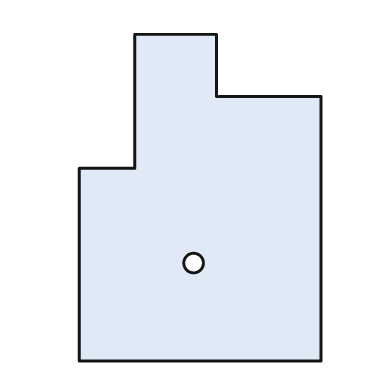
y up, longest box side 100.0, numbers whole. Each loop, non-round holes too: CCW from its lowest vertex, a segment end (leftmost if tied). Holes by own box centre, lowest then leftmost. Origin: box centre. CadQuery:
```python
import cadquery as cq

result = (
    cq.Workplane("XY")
    .moveTo(-37.0, -50.0)
    .lineTo(37.0, -50.0)
    .lineTo(37.0, 31.0)
    .lineTo(5.0, 31.0)
    .lineTo(5.0, 50.0)
    .lineTo(-20.0, 50.0)
    .lineTo(-20.0, 9.0)
    .lineTo(-37.0, 9.0)
    .close()
    .moveTo(-2.0, -20.0)
    .circle(3.0)
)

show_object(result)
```